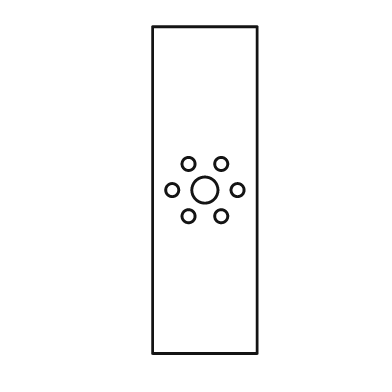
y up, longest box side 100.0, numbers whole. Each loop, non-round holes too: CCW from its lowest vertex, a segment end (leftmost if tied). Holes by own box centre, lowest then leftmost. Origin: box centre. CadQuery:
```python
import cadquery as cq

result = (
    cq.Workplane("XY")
    .moveTo(-16.0, -50.0)
    .lineTo(16.0, -50.0)
    .lineTo(16.0, 50.0)
    .lineTo(-16.0, 50.0)
    .close()
    .moveTo(-5.0, -8.0)
    .circle(2.0)
    .moveTo(5.0, -8.0)
    .circle(2.0)
    .moveTo(-10.0, 0.0)
    .circle(2.0)
    .moveTo(0.0, 0.0)
    .circle(4.0)
    .moveTo(10.0, 0.0)
    .circle(2.0)
    .moveTo(-5.0, 8.0)
    .circle(2.0)
    .moveTo(5.0, 8.0)
    .circle(2.0)
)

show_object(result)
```